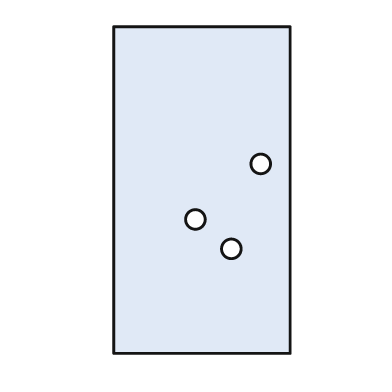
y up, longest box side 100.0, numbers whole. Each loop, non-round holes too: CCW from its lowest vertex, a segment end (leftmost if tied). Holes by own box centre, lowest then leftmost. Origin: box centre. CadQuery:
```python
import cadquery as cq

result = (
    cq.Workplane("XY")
    .moveTo(-27.0, -50.0)
    .lineTo(27.0, -50.0)
    .lineTo(27.0, 50.0)
    .lineTo(-27.0, 50.0)
    .close()
    .moveTo(9.0, -18.0)
    .circle(3.0)
    .moveTo(-2.0, -9.0)
    .circle(3.0)
    .moveTo(18.0, 8.0)
    .circle(3.0)
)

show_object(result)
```